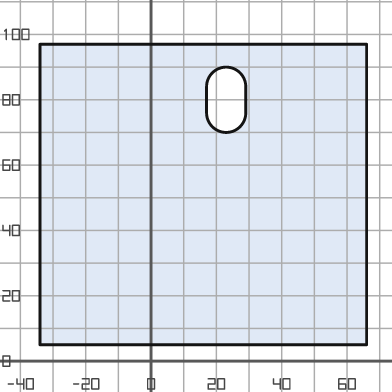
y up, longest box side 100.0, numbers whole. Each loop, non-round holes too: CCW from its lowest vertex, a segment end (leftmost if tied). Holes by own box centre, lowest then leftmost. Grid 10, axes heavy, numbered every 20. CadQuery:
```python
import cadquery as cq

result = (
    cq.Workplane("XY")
    .moveTo(-34.0, 5.0)
    .lineTo(66.0, 5.0)
    .lineTo(66.0, 97.0)
    .lineTo(-34.0, 97.0)
    .close()
    .moveTo(17.0, 76.0)
    .threePointArc((23.0, 70.0), (29.0, 76.0))
    .lineTo(29.0, 84.0)
    .threePointArc((23.0, 90.0), (17.0, 84.0))
    .close()
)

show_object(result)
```